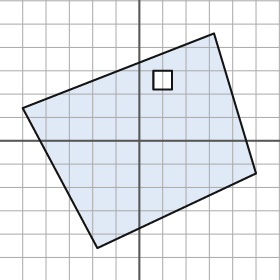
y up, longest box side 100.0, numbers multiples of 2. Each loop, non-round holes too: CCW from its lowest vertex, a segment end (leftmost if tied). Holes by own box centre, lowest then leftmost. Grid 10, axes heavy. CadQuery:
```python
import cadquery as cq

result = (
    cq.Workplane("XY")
    .moveTo(-18.0, -46.0)
    .lineTo(50.0, -14.0)
    .lineTo(32.0, 46.0)
    .lineTo(-50.0, 14.0)
    .close()
    .moveTo(6.0, 22.0)
    .lineTo(14.0, 22.0)
    .lineTo(14.0, 30.0)
    .lineTo(6.0, 30.0)
    .close()
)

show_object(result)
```